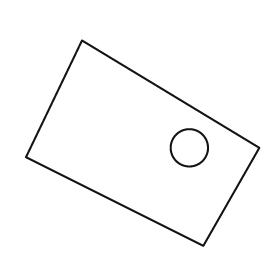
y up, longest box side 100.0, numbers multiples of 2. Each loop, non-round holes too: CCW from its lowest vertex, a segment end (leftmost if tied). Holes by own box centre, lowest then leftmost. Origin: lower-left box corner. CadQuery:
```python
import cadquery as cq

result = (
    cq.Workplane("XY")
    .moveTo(76.0, 0.0)
    .lineTo(100.0, 42.0)
    .lineTo(24.0, 88.0)
    .lineTo(0.0, 38.0)
    .close()
    .moveTo(70.0, 42.0)
    .circle(8.0)
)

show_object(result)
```